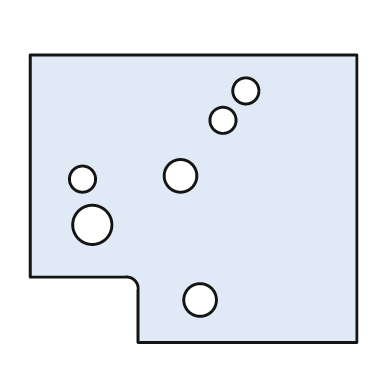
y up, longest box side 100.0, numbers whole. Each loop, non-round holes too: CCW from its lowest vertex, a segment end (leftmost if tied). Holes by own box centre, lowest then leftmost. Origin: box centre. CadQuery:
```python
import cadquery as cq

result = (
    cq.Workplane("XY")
    .moveTo(-17.0, -44.0)
    .lineTo(50.0, -44.0)
    .lineTo(50.0, 44.0)
    .lineTo(-50.0, 44.0)
    .lineTo(-50.0, -24.0)
    .lineTo(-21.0, -24.0)
    .threePointArc((-18.0, -25.0), (-17.0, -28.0))
    .close()
    .moveTo(2.0, -31.0)
    .circle(5.0)
    .moveTo(-31.0, -8.0)
    .circle(6.0)
    .moveTo(-34.0, 6.0)
    .circle(4.0)
    .moveTo(-4.0, 7.0)
    .circle(5.0)
    .moveTo(9.0, 24.0)
    .circle(4.0)
    .moveTo(16.0, 33.0)
    .circle(4.0)
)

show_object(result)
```